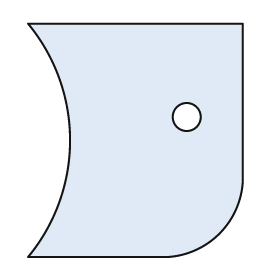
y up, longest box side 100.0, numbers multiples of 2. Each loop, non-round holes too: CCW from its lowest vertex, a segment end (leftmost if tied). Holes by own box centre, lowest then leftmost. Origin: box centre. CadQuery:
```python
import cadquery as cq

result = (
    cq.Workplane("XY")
    .moveTo(-46.0, -50.0)
    .lineTo(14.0, -50.0)
    .threePointArc((36.0, -40.0), (46.0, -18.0))
    .lineTo(46.0, 50.0)
    .lineTo(-46.0, 50.0)
    .threePointArc((-28.0, 0.0), (-46.0, -50.0))
    .close()
    .moveTo(22.0, 10.0)
    .circle(6.0)
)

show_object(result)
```